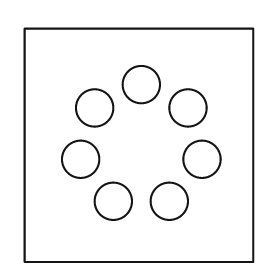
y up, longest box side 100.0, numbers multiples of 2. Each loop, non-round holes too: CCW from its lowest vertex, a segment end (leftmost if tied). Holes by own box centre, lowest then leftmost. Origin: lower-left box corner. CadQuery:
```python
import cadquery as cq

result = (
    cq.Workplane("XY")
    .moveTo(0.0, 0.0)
    .lineTo(98.0, 0.0)
    .lineTo(98.0, 100.0)
    .lineTo(0.0, 100.0)
    .close()
    .moveTo(38.0, 26.0)
    .circle(8.0)
    .moveTo(62.0, 26.0)
    .circle(8.0)
    .moveTo(24.0, 44.0)
    .circle(8.0)
    .moveTo(76.0, 44.0)
    .circle(8.0)
    .moveTo(30.0, 66.0)
    .circle(8.0)
    .moveTo(70.0, 66.0)
    .circle(8.0)
    .moveTo(50.0, 76.0)
    .circle(8.0)
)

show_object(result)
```